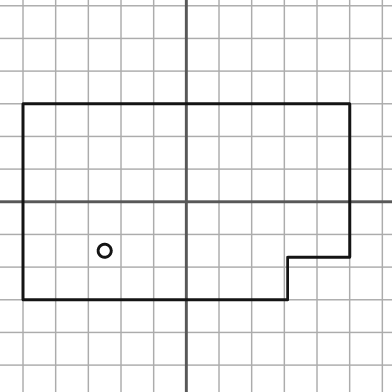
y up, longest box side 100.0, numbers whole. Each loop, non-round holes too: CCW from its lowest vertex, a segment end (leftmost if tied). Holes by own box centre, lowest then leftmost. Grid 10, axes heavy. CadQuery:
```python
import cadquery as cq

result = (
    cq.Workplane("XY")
    .moveTo(-50.0, -30.0)
    .lineTo(31.0, -30.0)
    .lineTo(31.0, -17.0)
    .lineTo(50.0, -17.0)
    .lineTo(50.0, 30.0)
    .lineTo(-50.0, 30.0)
    .close()
    .moveTo(-25.0, -15.0)
    .circle(2.0)
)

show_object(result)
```